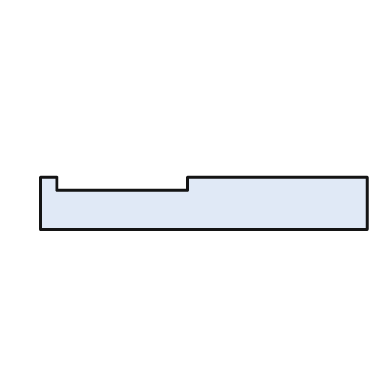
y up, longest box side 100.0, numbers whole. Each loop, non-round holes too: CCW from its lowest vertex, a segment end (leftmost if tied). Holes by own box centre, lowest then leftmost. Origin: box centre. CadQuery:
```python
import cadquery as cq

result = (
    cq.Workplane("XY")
    .moveTo(-50.0, -8.0)
    .lineTo(50.0, -8.0)
    .lineTo(50.0, 8.0)
    .lineTo(-5.0, 8.0)
    .lineTo(-5.0, 4.0)
    .lineTo(-45.0, 4.0)
    .lineTo(-45.0, 8.0)
    .lineTo(-50.0, 8.0)
    .close()
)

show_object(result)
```